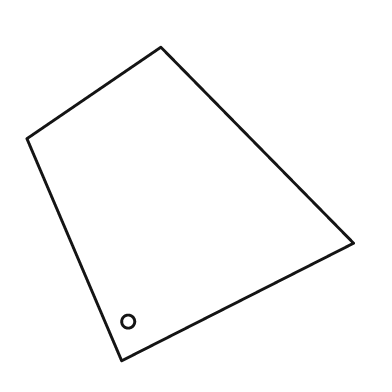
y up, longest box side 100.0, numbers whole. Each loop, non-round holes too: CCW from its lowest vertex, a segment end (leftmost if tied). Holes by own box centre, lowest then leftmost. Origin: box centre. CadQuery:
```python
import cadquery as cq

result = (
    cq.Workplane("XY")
    .moveTo(-21.0, -48.0)
    .lineTo(50.0, -12.0)
    .lineTo(-9.0, 48.0)
    .lineTo(-50.0, 20.0)
    .close()
    .moveTo(-19.0, -36.0)
    .circle(2.0)
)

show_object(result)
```